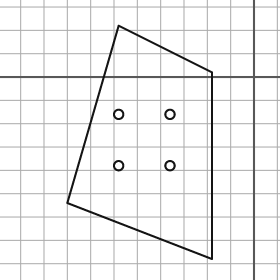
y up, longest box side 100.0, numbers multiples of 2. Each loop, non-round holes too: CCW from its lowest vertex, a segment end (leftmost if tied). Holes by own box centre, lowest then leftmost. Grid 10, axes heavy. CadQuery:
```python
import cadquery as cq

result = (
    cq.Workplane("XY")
    .moveTo(-18.0, -78.0)
    .lineTo(-18.0, 2.0)
    .lineTo(-58.0, 22.0)
    .lineTo(-80.0, -54.0)
    .close()
    .moveTo(-58.0, -38.0)
    .circle(2.0)
    .moveTo(-36.0, -38.0)
    .circle(2.0)
    .moveTo(-58.0, -16.0)
    .circle(2.0)
    .moveTo(-36.0, -16.0)
    .circle(2.0)
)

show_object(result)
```